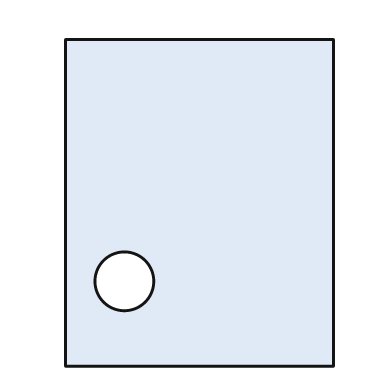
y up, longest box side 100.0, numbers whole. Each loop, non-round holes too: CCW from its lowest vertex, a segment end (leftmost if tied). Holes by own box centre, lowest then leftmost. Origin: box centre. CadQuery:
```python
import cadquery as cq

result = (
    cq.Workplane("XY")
    .moveTo(-41.0, -50.0)
    .lineTo(41.0, -50.0)
    .lineTo(41.0, 50.0)
    .lineTo(-41.0, 50.0)
    .close()
    .moveTo(-23.0, -24.0)
    .circle(9.0)
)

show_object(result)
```